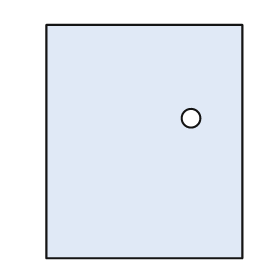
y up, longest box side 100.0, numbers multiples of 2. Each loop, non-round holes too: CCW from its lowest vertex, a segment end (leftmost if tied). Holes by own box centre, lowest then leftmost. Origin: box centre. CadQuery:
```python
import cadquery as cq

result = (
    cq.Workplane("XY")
    .moveTo(-42.0, -50.0)
    .lineTo(42.0, -50.0)
    .lineTo(42.0, 50.0)
    .lineTo(-42.0, 50.0)
    .close()
    .moveTo(20.0, 10.0)
    .circle(4.0)
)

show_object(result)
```